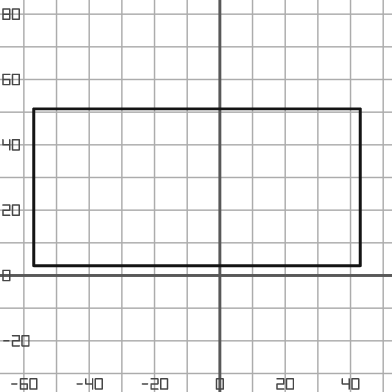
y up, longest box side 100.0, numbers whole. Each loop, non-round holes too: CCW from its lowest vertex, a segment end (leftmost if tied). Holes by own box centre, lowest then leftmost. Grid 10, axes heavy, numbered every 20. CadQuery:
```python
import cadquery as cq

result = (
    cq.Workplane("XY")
    .moveTo(-57.0, 3.0)
    .lineTo(43.0, 3.0)
    .lineTo(43.0, 51.0)
    .lineTo(-57.0, 51.0)
    .close()
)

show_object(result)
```